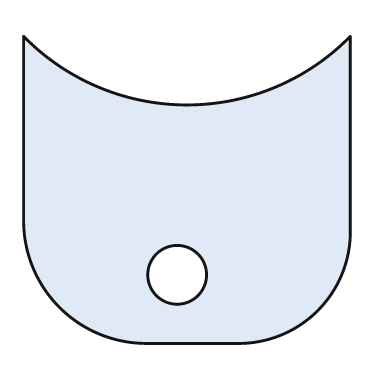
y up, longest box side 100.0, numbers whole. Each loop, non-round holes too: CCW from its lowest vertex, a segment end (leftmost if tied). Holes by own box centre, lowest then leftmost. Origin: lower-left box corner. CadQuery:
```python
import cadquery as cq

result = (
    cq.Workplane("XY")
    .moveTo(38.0, 0.0)
    .lineTo(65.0, 0.0)
    .threePointArc((90.0, 10.0), (100.0, 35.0))
    .lineTo(100.0, 94.0)
    .threePointArc((50.0, 73.0), (0.0, 94.0))
    .lineTo(0.0, 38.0)
    .threePointArc((11.0, 11.0), (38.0, 0.0))
    .close()
    .moveTo(47.0, 21.0)
    .circle(9.0)
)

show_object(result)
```